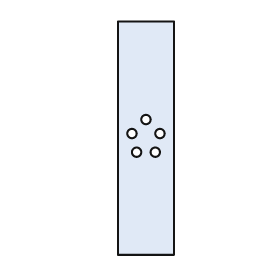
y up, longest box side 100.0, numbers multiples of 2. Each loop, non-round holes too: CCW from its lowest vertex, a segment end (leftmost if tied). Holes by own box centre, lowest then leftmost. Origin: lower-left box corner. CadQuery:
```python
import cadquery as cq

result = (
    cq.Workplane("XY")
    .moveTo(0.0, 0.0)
    .lineTo(24.0, 0.0)
    .lineTo(24.0, 100.0)
    .lineTo(0.0, 100.0)
    .close()
    .moveTo(8.0, 44.0)
    .circle(2.0)
    .moveTo(16.0, 44.0)
    .circle(2.0)
    .moveTo(6.0, 52.0)
    .circle(2.0)
    .moveTo(18.0, 52.0)
    .circle(2.0)
    .moveTo(12.0, 58.0)
    .circle(2.0)
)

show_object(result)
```